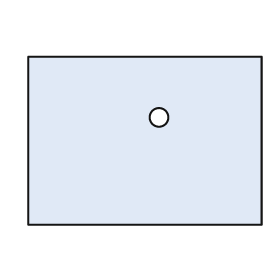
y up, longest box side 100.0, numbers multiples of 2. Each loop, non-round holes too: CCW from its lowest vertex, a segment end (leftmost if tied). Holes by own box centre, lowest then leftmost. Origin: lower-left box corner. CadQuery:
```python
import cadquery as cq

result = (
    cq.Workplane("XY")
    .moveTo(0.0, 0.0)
    .lineTo(100.0, 0.0)
    .lineTo(100.0, 72.0)
    .lineTo(0.0, 72.0)
    .close()
    .moveTo(56.0, 46.0)
    .circle(4.0)
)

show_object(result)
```